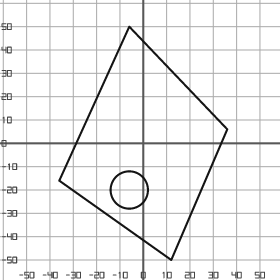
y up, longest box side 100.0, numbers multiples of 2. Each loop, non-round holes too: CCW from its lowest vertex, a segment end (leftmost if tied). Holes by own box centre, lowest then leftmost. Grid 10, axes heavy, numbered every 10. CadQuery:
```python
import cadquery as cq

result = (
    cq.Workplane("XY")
    .moveTo(12.0, -50.0)
    .lineTo(36.0, 6.0)
    .lineTo(-6.0, 50.0)
    .lineTo(-36.0, -16.0)
    .close()
    .moveTo(-6.0, -20.0)
    .circle(8.0)
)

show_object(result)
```